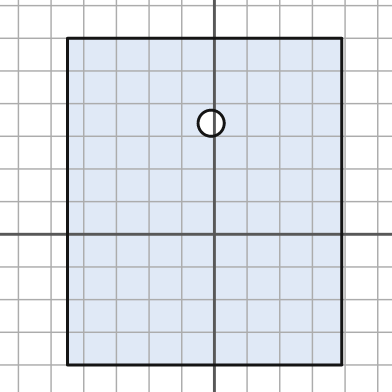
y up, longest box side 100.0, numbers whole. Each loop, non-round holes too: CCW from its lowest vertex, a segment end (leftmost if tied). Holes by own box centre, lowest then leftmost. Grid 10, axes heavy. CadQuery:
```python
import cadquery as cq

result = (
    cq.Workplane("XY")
    .moveTo(-45.0, -40.0)
    .lineTo(39.0, -40.0)
    .lineTo(39.0, 60.0)
    .lineTo(-45.0, 60.0)
    .close()
    .moveTo(-1.0, 34.0)
    .circle(4.0)
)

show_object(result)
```